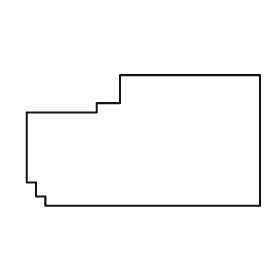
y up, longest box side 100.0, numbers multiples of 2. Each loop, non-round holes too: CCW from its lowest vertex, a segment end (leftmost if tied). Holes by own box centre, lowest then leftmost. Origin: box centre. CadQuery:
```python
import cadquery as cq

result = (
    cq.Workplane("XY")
    .moveTo(-42.0, -28.0)
    .lineTo(50.0, -28.0)
    .lineTo(50.0, 28.0)
    .lineTo(-10.0, 28.0)
    .lineTo(-10.0, 16.0)
    .lineTo(-20.0, 16.0)
    .lineTo(-20.0, 12.0)
    .lineTo(-50.0, 12.0)
    .lineTo(-50.0, -18.0)
    .lineTo(-46.0, -18.0)
    .lineTo(-46.0, -24.0)
    .lineTo(-42.0, -24.0)
    .close()
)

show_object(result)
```